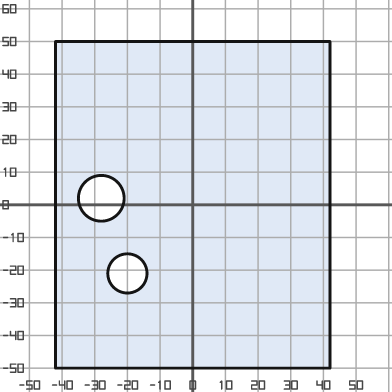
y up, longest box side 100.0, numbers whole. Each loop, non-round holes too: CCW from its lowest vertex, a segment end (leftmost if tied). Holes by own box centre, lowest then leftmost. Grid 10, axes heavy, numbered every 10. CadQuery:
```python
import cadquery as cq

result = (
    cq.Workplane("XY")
    .moveTo(-42.0, -50.0)
    .lineTo(42.0, -50.0)
    .lineTo(42.0, 50.0)
    .lineTo(-42.0, 50.0)
    .close()
    .moveTo(-20.0, -21.0)
    .circle(6.0)
    .moveTo(-28.0, 2.0)
    .circle(7.0)
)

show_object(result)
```